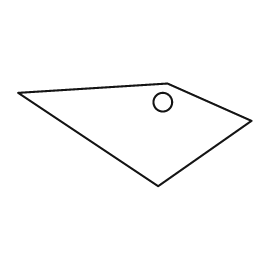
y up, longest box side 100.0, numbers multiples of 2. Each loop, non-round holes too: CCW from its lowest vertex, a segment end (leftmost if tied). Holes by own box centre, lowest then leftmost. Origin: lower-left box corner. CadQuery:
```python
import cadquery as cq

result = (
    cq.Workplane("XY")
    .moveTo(60.0, 0.0)
    .lineTo(100.0, 28.0)
    .lineTo(64.0, 44.0)
    .lineTo(0.0, 40.0)
    .close()
    .moveTo(62.0, 36.0)
    .circle(4.0)
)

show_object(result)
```